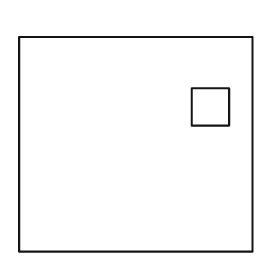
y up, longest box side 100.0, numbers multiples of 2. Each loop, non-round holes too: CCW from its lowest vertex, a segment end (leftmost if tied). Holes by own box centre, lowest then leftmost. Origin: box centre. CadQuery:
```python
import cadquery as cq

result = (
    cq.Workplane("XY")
    .moveTo(-50.0, -46.0)
    .lineTo(50.0, -46.0)
    .lineTo(50.0, 46.0)
    .lineTo(-50.0, 46.0)
    .close()
    .moveTo(24.0, 8.0)
    .lineTo(40.0, 8.0)
    .lineTo(40.0, 24.0)
    .lineTo(24.0, 24.0)
    .close()
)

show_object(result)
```